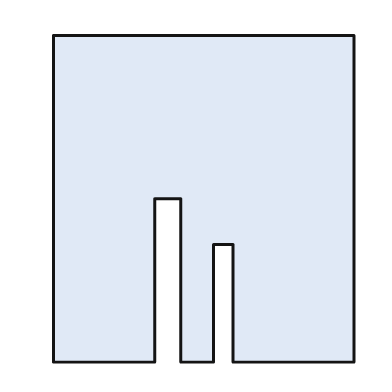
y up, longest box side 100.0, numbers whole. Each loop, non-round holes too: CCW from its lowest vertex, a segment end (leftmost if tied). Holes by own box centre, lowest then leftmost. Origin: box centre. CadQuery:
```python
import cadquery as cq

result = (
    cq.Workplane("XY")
    .moveTo(-46.0, -50.0)
    .lineTo(-15.0, -50.0)
    .lineTo(-15.0, 0.0)
    .lineTo(-7.0, 0.0)
    .lineTo(-7.0, -50.0)
    .lineTo(3.0, -50.0)
    .lineTo(3.0, -14.0)
    .lineTo(9.0, -14.0)
    .lineTo(9.0, -50.0)
    .lineTo(46.0, -50.0)
    .lineTo(46.0, 50.0)
    .lineTo(-46.0, 50.0)
    .close()
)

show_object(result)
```